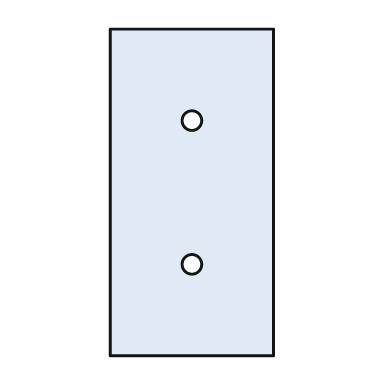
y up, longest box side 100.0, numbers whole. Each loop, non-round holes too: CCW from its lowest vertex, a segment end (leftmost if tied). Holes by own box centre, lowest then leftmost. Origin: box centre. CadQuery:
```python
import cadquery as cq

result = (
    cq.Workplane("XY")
    .moveTo(-25.0, -50.0)
    .lineTo(25.0, -50.0)
    .lineTo(25.0, 50.0)
    .lineTo(-25.0, 50.0)
    .close()
    .moveTo(0.0, -22.0)
    .circle(3.0)
    .moveTo(0.0, 22.0)
    .circle(3.0)
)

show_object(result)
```